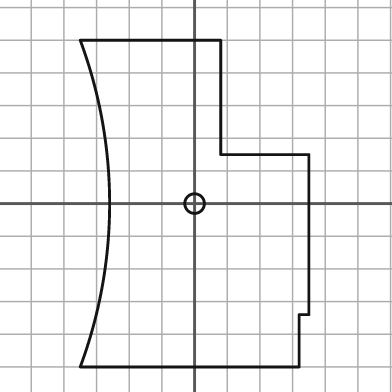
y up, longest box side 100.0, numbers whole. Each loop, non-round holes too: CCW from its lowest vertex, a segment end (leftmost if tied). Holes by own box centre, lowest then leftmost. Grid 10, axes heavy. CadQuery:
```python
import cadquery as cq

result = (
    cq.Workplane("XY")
    .moveTo(-35.0, -50.0)
    .lineTo(32.0, -50.0)
    .lineTo(32.0, -34.0)
    .lineTo(35.0, -34.0)
    .lineTo(35.0, 15.0)
    .lineTo(8.0, 15.0)
    .lineTo(8.0, 50.0)
    .lineTo(-35.0, 50.0)
    .threePointArc((-26.0, 0.0), (-35.0, -50.0))
    .close()
    .moveTo(0.0, 0.0)
    .circle(3.0)
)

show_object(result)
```